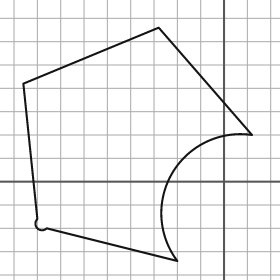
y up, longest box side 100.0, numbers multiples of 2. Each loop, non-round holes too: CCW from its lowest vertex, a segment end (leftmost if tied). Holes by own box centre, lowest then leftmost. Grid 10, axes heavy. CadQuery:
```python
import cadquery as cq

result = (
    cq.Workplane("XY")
    .moveTo(-20.0, -34.0)
    .threePointArc((-22.0, 4.0), (12.0, 20.0))
    .lineTo(-28.0, 66.0)
    .lineTo(-86.0, 42.0)
    .lineTo(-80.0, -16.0)
    .threePointArc((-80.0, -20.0), (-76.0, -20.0))
    .close()
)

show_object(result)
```